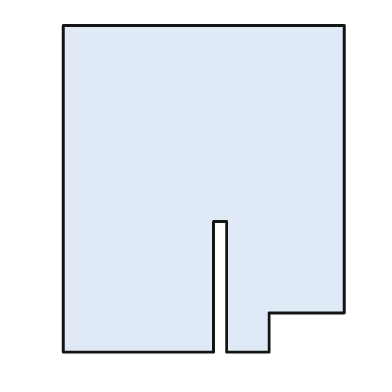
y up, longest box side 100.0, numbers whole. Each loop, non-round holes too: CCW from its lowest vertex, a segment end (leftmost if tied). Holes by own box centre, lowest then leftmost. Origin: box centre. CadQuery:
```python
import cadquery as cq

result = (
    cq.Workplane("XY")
    .moveTo(-43.0, -50.0)
    .lineTo(3.0, -50.0)
    .lineTo(3.0, -10.0)
    .lineTo(7.0, -10.0)
    .lineTo(7.0, -50.0)
    .lineTo(20.0, -50.0)
    .lineTo(20.0, -38.0)
    .lineTo(43.0, -38.0)
    .lineTo(43.0, 50.0)
    .lineTo(-43.0, 50.0)
    .close()
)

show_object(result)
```